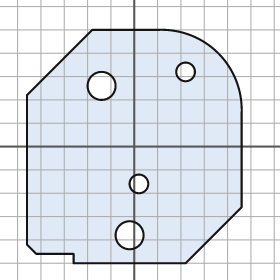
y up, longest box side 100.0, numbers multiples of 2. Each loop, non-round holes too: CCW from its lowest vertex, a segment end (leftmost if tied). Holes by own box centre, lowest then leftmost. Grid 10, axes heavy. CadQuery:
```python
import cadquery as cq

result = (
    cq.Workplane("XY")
    .moveTo(-26.0, -50.0)
    .lineTo(22.0, -50.0)
    .lineTo(46.0, -26.0)
    .lineTo(46.0, 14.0)
    .threePointArc((36.0, 40.0), (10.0, 50.0))
    .lineTo(-18.0, 50.0)
    .lineTo(-46.0, 22.0)
    .lineTo(-46.0, -42.0)
    .lineTo(-42.0, -46.0)
    .lineTo(-26.0, -46.0)
    .close()
    .moveTo(-2.0, -38.0)
    .circle(6.0)
    .moveTo(2.0, -16.0)
    .circle(4.0)
    .moveTo(-14.0, 26.0)
    .circle(6.0)
    .moveTo(22.0, 32.0)
    .circle(4.0)
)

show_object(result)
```